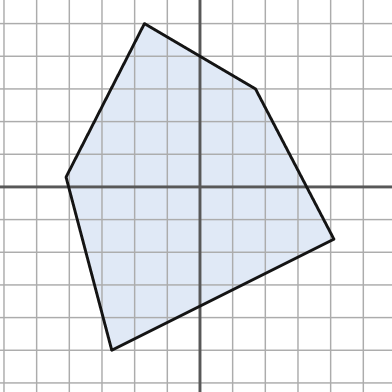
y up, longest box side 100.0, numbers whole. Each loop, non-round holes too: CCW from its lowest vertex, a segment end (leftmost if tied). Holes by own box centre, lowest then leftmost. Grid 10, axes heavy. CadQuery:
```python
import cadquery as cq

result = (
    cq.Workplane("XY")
    .moveTo(-27.0, -50.0)
    .lineTo(41.0, -16.0)
    .lineTo(17.0, 30.0)
    .lineTo(-17.0, 50.0)
    .lineTo(-41.0, 3.0)
    .close()
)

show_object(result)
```